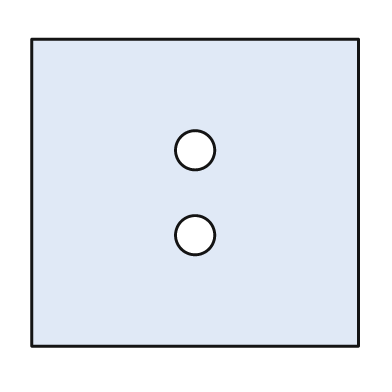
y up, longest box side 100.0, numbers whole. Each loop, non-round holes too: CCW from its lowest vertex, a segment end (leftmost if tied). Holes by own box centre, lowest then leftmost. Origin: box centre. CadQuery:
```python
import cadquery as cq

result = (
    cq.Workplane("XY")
    .moveTo(-50.0, -47.0)
    .lineTo(50.0, -47.0)
    .lineTo(50.0, 47.0)
    .lineTo(-50.0, 47.0)
    .close()
    .moveTo(0.0, -13.0)
    .circle(6.0)
    .moveTo(0.0, 13.0)
    .circle(6.0)
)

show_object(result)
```